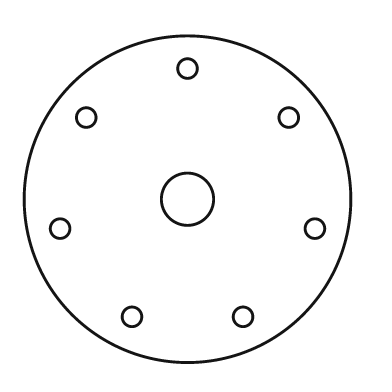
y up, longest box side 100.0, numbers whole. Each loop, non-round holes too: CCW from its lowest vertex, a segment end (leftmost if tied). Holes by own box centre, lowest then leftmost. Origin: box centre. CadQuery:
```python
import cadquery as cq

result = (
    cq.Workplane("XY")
    .moveTo(0.0, 0.0)
    .circle(50.0)
    .moveTo(-17.0, -36.0)
    .circle(3.0)
    .moveTo(17.0, -36.0)
    .circle(3.0)
    .moveTo(-39.0, -9.0)
    .circle(3.0)
    .moveTo(39.0, -9.0)
    .circle(3.0)
    .moveTo(0.0, 0.0)
    .circle(8.0)
    .moveTo(-31.0, 25.0)
    .circle(3.0)
    .moveTo(31.0, 25.0)
    .circle(3.0)
    .moveTo(0.0, 40.0)
    .circle(3.0)
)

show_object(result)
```